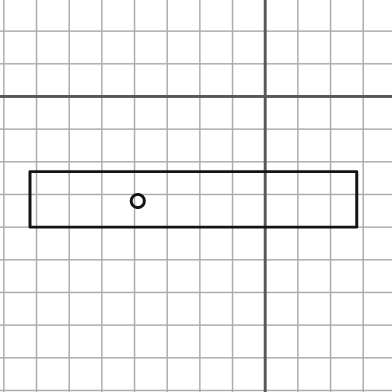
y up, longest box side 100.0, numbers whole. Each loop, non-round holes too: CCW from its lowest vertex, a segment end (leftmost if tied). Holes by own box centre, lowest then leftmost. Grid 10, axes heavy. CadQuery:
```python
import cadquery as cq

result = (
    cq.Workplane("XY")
    .moveTo(-72.0, -40.0)
    .lineTo(28.0, -40.0)
    .lineTo(28.0, -23.0)
    .lineTo(-72.0, -23.0)
    .close()
    .moveTo(-39.0, -32.0)
    .circle(2.0)
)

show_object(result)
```